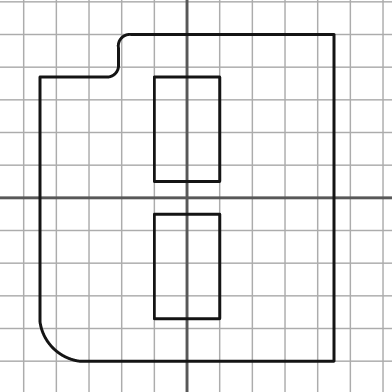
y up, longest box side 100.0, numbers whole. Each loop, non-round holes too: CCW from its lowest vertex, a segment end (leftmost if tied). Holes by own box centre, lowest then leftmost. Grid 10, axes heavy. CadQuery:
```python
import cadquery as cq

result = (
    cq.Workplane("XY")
    .moveTo(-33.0, -50.0)
    .lineTo(45.0, -50.0)
    .lineTo(45.0, 50.0)
    .lineTo(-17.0, 50.0)
    .threePointArc((-20.0, 49.0), (-21.0, 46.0))
    .lineTo(-21.0, 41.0)
    .threePointArc((-22.0, 38.0), (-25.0, 37.0))
    .lineTo(-45.0, 37.0)
    .lineTo(-45.0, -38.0)
    .threePointArc((-41.0, -46.0), (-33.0, -50.0))
    .close()
    .moveTo(-10.0, -37.0)
    .lineTo(10.0, -37.0)
    .lineTo(10.0, -5.0)
    .lineTo(-10.0, -5.0)
    .close()
    .moveTo(-10.0, 5.0)
    .lineTo(10.0, 5.0)
    .lineTo(10.0, 37.0)
    .lineTo(-10.0, 37.0)
    .close()
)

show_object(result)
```